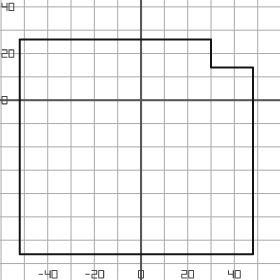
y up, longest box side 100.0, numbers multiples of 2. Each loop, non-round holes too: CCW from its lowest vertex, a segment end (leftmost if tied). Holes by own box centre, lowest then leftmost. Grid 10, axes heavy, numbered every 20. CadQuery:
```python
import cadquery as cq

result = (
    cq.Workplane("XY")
    .moveTo(-52.0, -66.0)
    .lineTo(48.0, -66.0)
    .lineTo(48.0, 14.0)
    .lineTo(30.0, 14.0)
    .lineTo(30.0, 26.0)
    .lineTo(-52.0, 26.0)
    .close()
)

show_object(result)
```